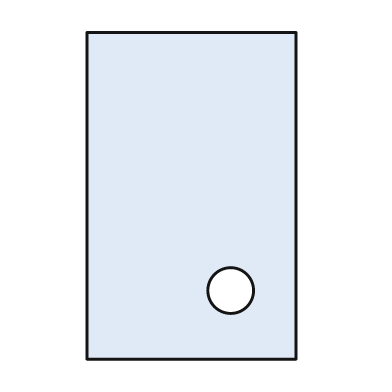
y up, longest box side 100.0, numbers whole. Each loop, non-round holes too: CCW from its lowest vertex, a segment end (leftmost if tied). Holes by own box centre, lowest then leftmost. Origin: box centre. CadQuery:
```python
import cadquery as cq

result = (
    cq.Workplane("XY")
    .moveTo(-32.0, -50.0)
    .lineTo(32.0, -50.0)
    .lineTo(32.0, 50.0)
    .lineTo(-32.0, 50.0)
    .close()
    .moveTo(12.0, -29.0)
    .circle(7.0)
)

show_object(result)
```